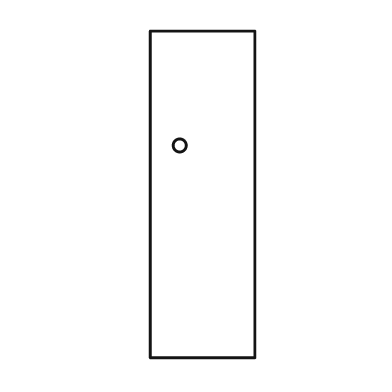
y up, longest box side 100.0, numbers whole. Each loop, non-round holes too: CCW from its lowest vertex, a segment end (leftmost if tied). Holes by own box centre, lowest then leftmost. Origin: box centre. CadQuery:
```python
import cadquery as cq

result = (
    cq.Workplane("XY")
    .moveTo(-16.0, -50.0)
    .lineTo(16.0, -50.0)
    .lineTo(16.0, 50.0)
    .lineTo(-16.0, 50.0)
    .close()
    .moveTo(-7.0, 15.0)
    .circle(2.0)
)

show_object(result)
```